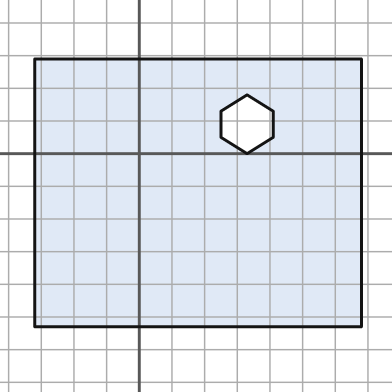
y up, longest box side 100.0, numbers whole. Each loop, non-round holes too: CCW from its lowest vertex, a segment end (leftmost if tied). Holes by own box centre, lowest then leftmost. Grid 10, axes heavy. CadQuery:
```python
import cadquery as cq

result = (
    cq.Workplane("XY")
    .moveTo(-32.0, -53.0)
    .lineTo(68.0, -53.0)
    .lineTo(68.0, 29.0)
    .lineTo(-32.0, 29.0)
    .close()
    .moveTo(33.0, 0.0)
    .lineTo(41.0, 5.0)
    .lineTo(41.0, 13.0)
    .lineTo(33.0, 18.0)
    .lineTo(25.0, 13.0)
    .lineTo(25.0, 5.0)
    .close()
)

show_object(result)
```